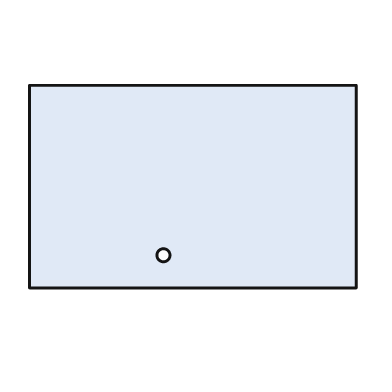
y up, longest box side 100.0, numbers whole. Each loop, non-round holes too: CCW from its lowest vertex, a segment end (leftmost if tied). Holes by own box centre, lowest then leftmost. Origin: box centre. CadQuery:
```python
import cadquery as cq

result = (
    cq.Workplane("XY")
    .moveTo(-50.0, -31.0)
    .lineTo(50.0, -31.0)
    .lineTo(50.0, 31.0)
    .lineTo(-50.0, 31.0)
    .close()
    .moveTo(-9.0, -21.0)
    .circle(2.0)
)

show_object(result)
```